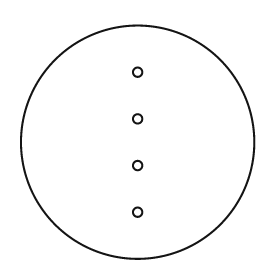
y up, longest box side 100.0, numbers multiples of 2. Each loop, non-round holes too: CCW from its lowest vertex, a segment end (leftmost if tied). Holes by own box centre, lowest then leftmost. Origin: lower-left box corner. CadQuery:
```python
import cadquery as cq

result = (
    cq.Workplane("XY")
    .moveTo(50.0, 50.0)
    .circle(50.0)
    .moveTo(50.0, 20.0)
    .circle(2.0)
    .moveTo(50.0, 40.0)
    .circle(2.0)
    .moveTo(50.0, 60.0)
    .circle(2.0)
    .moveTo(50.0, 80.0)
    .circle(2.0)
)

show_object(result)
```